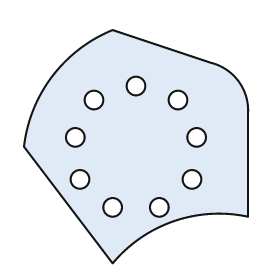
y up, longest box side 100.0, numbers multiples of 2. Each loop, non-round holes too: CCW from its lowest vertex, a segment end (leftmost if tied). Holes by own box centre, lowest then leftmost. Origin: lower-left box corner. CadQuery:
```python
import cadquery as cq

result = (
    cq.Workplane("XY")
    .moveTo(38.0, 0.0)
    .threePointArc((64.0, 18.0), (96.0, 20.0))
    .lineTo(96.0, 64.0)
    .threePointArc((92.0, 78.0), (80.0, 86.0))
    .lineTo(38.0, 100.0)
    .threePointArc((12.0, 80.0), (0.0, 50.0))
    .close()
    .moveTo(38.0, 24.0)
    .circle(4.0)
    .moveTo(58.0, 24.0)
    .circle(4.0)
    .moveTo(24.0, 36.0)
    .circle(4.0)
    .moveTo(72.0, 36.0)
    .circle(4.0)
    .moveTo(22.0, 54.0)
    .circle(4.0)
    .moveTo(74.0, 54.0)
    .circle(4.0)
    .moveTo(30.0, 70.0)
    .circle(4.0)
    .moveTo(66.0, 70.0)
    .circle(4.0)
    .moveTo(48.0, 76.0)
    .circle(4.0)
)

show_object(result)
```